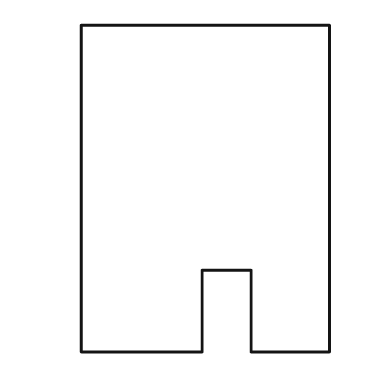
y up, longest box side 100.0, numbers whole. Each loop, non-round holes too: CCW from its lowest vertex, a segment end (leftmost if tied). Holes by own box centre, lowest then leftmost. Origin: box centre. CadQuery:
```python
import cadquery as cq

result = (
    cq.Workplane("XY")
    .moveTo(-38.0, -50.0)
    .lineTo(-1.0, -50.0)
    .lineTo(-1.0, -25.0)
    .lineTo(14.0, -25.0)
    .lineTo(14.0, -50.0)
    .lineTo(38.0, -50.0)
    .lineTo(38.0, 50.0)
    .lineTo(-38.0, 50.0)
    .close()
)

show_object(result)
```